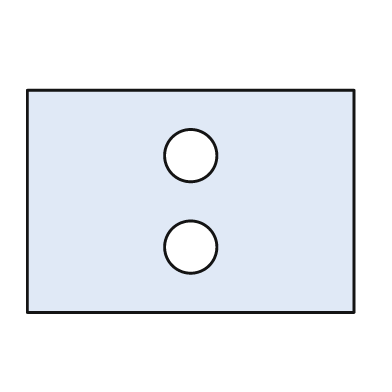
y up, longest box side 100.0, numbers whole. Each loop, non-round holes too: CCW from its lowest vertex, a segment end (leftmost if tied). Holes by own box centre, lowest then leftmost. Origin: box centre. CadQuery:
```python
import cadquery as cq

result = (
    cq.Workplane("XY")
    .moveTo(-50.0, -34.0)
    .lineTo(50.0, -34.0)
    .lineTo(50.0, 34.0)
    .lineTo(-50.0, 34.0)
    .close()
    .moveTo(0.0, -14.0)
    .circle(8.0)
    .moveTo(0.0, 14.0)
    .circle(8.0)
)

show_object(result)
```